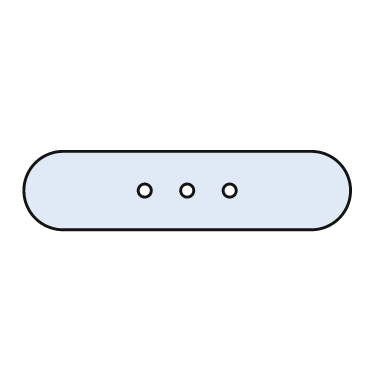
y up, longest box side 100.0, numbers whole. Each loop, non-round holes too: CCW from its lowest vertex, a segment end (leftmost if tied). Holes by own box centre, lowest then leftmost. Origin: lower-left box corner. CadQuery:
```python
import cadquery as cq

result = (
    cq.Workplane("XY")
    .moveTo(12.0, 0.0)
    .lineTo(88.0, 0.0)
    .threePointArc((100.0, 12.0), (88.0, 24.0))
    .lineTo(12.0, 24.0)
    .threePointArc((0.0, 12.0), (12.0, 0.0))
    .close()
    .moveTo(37.0, 12.0)
    .circle(2.0)
    .moveTo(50.0, 12.0)
    .circle(2.0)
    .moveTo(63.0, 12.0)
    .circle(2.0)
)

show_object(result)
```